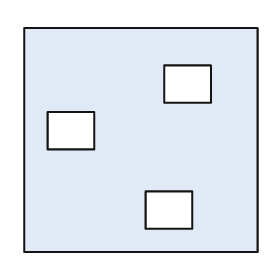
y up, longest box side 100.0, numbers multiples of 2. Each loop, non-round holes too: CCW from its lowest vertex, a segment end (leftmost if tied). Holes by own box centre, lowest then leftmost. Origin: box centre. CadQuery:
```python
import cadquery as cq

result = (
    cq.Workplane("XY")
    .moveTo(-50.0, -48.0)
    .lineTo(50.0, -48.0)
    .lineTo(50.0, 48.0)
    .lineTo(-50.0, 48.0)
    .close()
    .moveTo(2.0, -38.0)
    .lineTo(22.0, -38.0)
    .lineTo(22.0, -22.0)
    .lineTo(2.0, -22.0)
    .close()
    .moveTo(-40.0, -4.0)
    .lineTo(-20.0, -4.0)
    .lineTo(-20.0, 12.0)
    .lineTo(-40.0, 12.0)
    .close()
    .moveTo(10.0, 16.0)
    .lineTo(30.0, 16.0)
    .lineTo(30.0, 32.0)
    .lineTo(10.0, 32.0)
    .close()
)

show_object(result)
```